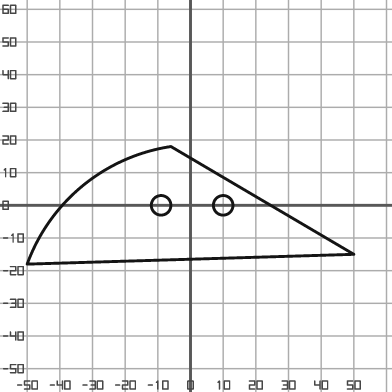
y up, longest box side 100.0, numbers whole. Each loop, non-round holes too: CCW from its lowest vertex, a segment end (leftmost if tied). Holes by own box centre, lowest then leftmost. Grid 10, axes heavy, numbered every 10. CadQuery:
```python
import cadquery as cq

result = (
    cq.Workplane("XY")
    .moveTo(-50.0, -18.0)
    .lineTo(50.0, -15.0)
    .lineTo(-6.0, 18.0)
    .threePointArc((-33.0, 6.0), (-50.0, -18.0))
    .close()
    .moveTo(-9.0, 0.0)
    .circle(3.0)
    .moveTo(10.0, 0.0)
    .circle(3.0)
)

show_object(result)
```